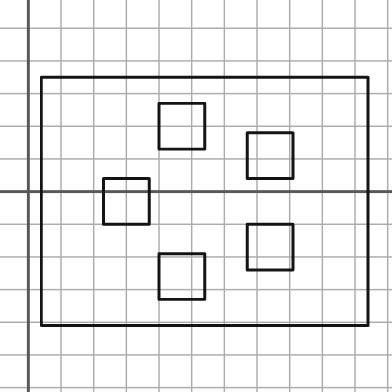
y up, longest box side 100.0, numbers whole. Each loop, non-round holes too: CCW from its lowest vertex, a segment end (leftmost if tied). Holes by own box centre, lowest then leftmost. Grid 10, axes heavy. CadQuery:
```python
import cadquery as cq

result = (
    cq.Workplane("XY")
    .moveTo(4.0, -41.0)
    .lineTo(104.0, -41.0)
    .lineTo(104.0, 35.0)
    .lineTo(4.0, 35.0)
    .close()
    .moveTo(40.0, -33.0)
    .lineTo(54.0, -33.0)
    .lineTo(54.0, -19.0)
    .lineTo(40.0, -19.0)
    .close()
    .moveTo(67.0, -24.0)
    .lineTo(81.0, -24.0)
    .lineTo(81.0, -10.0)
    .lineTo(67.0, -10.0)
    .close()
    .moveTo(23.0, -10.0)
    .lineTo(37.0, -10.0)
    .lineTo(37.0, 4.0)
    .lineTo(23.0, 4.0)
    .close()
    .moveTo(67.0, 4.0)
    .lineTo(81.0, 4.0)
    .lineTo(81.0, 18.0)
    .lineTo(67.0, 18.0)
    .close()
    .moveTo(40.0, 13.0)
    .lineTo(54.0, 13.0)
    .lineTo(54.0, 27.0)
    .lineTo(40.0, 27.0)
    .close()
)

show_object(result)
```